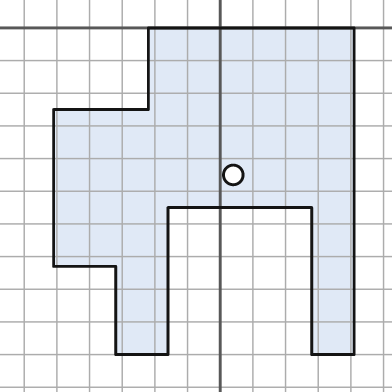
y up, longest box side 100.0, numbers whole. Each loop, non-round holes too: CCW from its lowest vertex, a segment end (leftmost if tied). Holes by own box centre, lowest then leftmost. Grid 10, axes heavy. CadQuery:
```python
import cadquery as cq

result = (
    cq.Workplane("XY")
    .moveTo(-32.0, -100.0)
    .lineTo(-16.0, -100.0)
    .lineTo(-16.0, -55.0)
    .lineTo(28.0, -55.0)
    .lineTo(28.0, -100.0)
    .lineTo(41.0, -100.0)
    .lineTo(41.0, 0.0)
    .lineTo(-22.0, 0.0)
    .lineTo(-22.0, -25.0)
    .lineTo(-51.0, -25.0)
    .lineTo(-51.0, -73.0)
    .lineTo(-32.0, -73.0)
    .close()
    .moveTo(4.0, -45.0)
    .circle(3.0)
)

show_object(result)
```